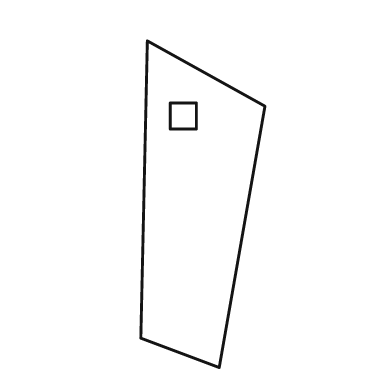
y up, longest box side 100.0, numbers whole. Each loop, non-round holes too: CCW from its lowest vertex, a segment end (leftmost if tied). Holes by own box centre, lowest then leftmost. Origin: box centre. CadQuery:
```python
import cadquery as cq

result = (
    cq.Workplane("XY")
    .moveTo(5.0, -50.0)
    .lineTo(19.0, 30.0)
    .lineTo(-17.0, 50.0)
    .lineTo(-19.0, -41.0)
    .close()
    .moveTo(-10.0, 23.0)
    .lineTo(-2.0, 23.0)
    .lineTo(-2.0, 31.0)
    .lineTo(-10.0, 31.0)
    .close()
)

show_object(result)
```